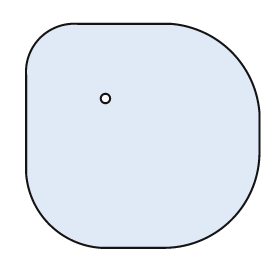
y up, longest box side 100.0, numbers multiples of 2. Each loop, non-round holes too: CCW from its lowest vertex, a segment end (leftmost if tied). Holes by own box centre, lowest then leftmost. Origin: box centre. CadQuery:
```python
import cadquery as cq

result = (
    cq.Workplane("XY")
    .moveTo(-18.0, -48.0)
    .lineTo(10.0, -48.0)
    .threePointArc((38.0, -36.0), (50.0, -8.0))
    .lineTo(50.0, 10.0)
    .threePointArc((38.0, 36.0), (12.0, 48.0))
    .lineTo(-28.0, 48.0)
    .threePointArc((-44.0, 42.0), (-50.0, 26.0))
    .lineTo(-50.0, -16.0)
    .threePointArc((-40.0, -38.0), (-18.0, -48.0))
    .close()
    .moveTo(-16.0, 16.0)
    .circle(2.0)
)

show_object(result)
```